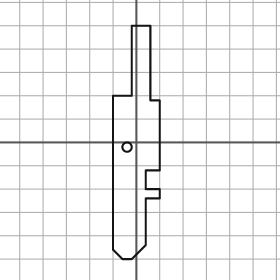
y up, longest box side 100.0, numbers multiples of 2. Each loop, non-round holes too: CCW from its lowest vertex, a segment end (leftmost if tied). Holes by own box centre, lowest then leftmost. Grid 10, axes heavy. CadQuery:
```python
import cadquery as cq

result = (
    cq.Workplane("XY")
    .moveTo(-6.0, -50.0)
    .lineTo(-2.0, -50.0)
    .lineTo(4.0, -44.0)
    .lineTo(4.0, -24.0)
    .lineTo(10.0, -24.0)
    .lineTo(10.0, -20.0)
    .lineTo(4.0, -20.0)
    .lineTo(4.0, -12.0)
    .lineTo(10.0, -12.0)
    .lineTo(10.0, 18.0)
    .lineTo(6.0, 18.0)
    .lineTo(6.0, 50.0)
    .lineTo(-2.0, 50.0)
    .lineTo(-2.0, 20.0)
    .lineTo(-10.0, 20.0)
    .lineTo(-10.0, -46.0)
    .close()
    .moveTo(-4.0, -2.0)
    .circle(2.0)
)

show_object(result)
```